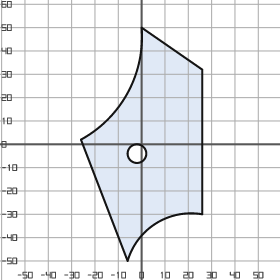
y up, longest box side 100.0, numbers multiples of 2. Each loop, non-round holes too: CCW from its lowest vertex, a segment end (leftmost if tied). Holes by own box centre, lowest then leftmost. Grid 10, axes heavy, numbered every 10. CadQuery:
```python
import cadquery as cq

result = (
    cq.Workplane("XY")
    .moveTo(-6.0, -50.0)
    .threePointArc((6.0, -34.0), (26.0, -30.0))
    .lineTo(26.0, 32.0)
    .lineTo(0.0, 50.0)
    .threePointArc((-6.0, 22.0), (-26.0, 2.0))
    .close()
    .moveTo(-2.0, -4.0)
    .circle(4.0)
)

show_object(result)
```